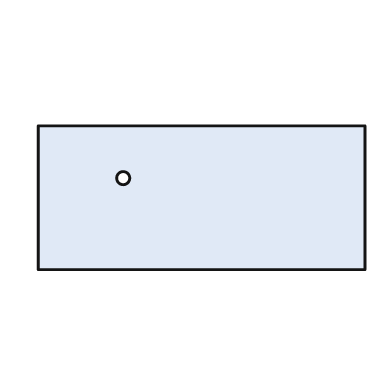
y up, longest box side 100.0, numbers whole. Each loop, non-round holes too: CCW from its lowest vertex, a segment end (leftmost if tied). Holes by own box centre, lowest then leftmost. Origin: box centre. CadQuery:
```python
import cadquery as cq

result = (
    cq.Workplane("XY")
    .moveTo(-50.0, -22.0)
    .lineTo(50.0, -22.0)
    .lineTo(50.0, 22.0)
    .lineTo(-50.0, 22.0)
    .close()
    .moveTo(-24.0, 6.0)
    .circle(2.0)
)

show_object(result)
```